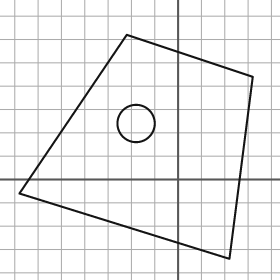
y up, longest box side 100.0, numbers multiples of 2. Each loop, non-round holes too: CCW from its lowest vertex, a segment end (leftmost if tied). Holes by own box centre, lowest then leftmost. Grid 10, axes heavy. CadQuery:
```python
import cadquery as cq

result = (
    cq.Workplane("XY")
    .moveTo(22.0, -34.0)
    .lineTo(32.0, 44.0)
    .lineTo(-22.0, 62.0)
    .lineTo(-68.0, -6.0)
    .close()
    .moveTo(-18.0, 24.0)
    .circle(8.0)
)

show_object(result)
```